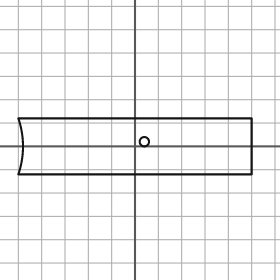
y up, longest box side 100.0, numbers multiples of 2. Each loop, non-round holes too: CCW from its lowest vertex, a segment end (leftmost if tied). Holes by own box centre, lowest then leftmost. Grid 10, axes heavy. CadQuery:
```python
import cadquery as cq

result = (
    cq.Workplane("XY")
    .moveTo(-50.0, -12.0)
    .lineTo(50.0, -12.0)
    .lineTo(50.0, 12.0)
    .lineTo(-50.0, 12.0)
    .threePointArc((-48.0, 0.0), (-50.0, -12.0))
    .close()
    .moveTo(4.0, 2.0)
    .circle(2.0)
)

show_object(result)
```